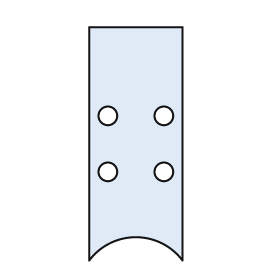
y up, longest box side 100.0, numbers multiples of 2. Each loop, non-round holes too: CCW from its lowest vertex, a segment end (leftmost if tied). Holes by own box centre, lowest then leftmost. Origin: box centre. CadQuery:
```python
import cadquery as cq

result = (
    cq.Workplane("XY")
    .moveTo(-20.0, -50.0)
    .threePointArc((0.0, -40.0), (20.0, -50.0))
    .lineTo(20.0, 50.0)
    .lineTo(-20.0, 50.0)
    .close()
    .moveTo(-12.0, -12.0)
    .circle(4.0)
    .moveTo(12.0, -12.0)
    .circle(4.0)
    .moveTo(-12.0, 12.0)
    .circle(4.0)
    .moveTo(12.0, 12.0)
    .circle(4.0)
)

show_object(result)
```